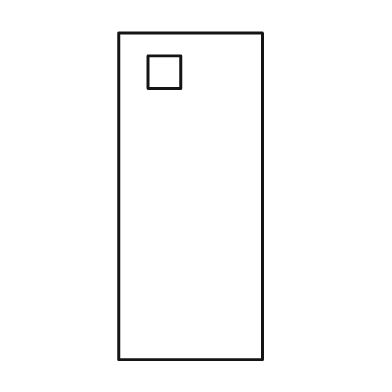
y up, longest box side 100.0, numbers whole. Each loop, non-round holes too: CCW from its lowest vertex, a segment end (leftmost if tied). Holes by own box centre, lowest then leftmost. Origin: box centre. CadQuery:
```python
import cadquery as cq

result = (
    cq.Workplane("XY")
    .moveTo(-22.0, -50.0)
    .lineTo(22.0, -50.0)
    .lineTo(22.0, 50.0)
    .lineTo(-22.0, 50.0)
    .close()
    .moveTo(-13.0, 33.0)
    .lineTo(-3.0, 33.0)
    .lineTo(-3.0, 43.0)
    .lineTo(-13.0, 43.0)
    .close()
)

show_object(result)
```